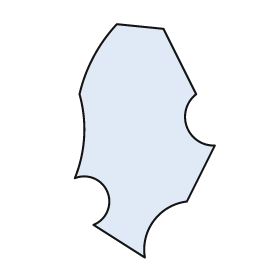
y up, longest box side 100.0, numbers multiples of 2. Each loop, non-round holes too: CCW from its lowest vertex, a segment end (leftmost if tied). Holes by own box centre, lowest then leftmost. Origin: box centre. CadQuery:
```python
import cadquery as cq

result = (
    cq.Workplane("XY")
    .moveTo(0.0, -50.0)
    .threePointArc((4.0, -34.0), (18.0, -26.0))
    .lineTo(30.0, -2.0)
    .threePointArc((18.0, 6.0), (22.0, 20.0))
    .lineTo(8.0, 48.0)
    .lineTo(-12.0, 50.0)
    .threePointArc((-22.0, 36.0), (-28.0, 20.0))
    .threePointArc((-26.0, 2.0), (-30.0, -16.0))
    .threePointArc((-16.0, -22.0), (-22.0, -36.0))
    .close()
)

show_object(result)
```